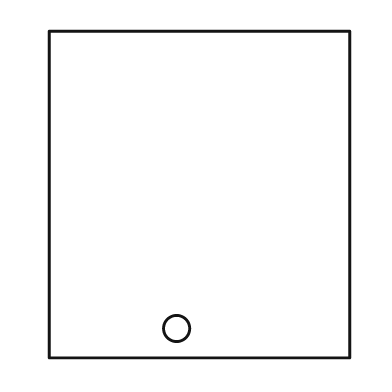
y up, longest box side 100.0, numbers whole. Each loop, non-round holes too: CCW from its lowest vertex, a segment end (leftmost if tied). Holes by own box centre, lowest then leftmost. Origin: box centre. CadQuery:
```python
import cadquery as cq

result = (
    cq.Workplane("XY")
    .moveTo(-46.0, -50.0)
    .lineTo(46.0, -50.0)
    .lineTo(46.0, 50.0)
    .lineTo(-46.0, 50.0)
    .close()
    .moveTo(-7.0, -41.0)
    .circle(4.0)
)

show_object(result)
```